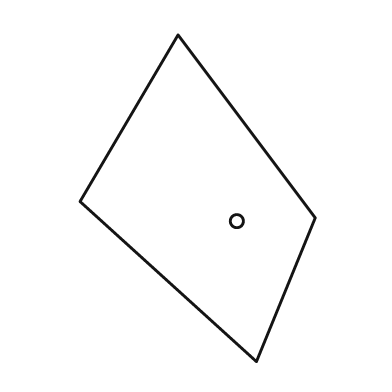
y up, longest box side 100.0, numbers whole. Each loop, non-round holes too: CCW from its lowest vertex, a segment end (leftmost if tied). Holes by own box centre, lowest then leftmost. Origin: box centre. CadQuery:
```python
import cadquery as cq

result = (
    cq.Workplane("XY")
    .moveTo(18.0, -50.0)
    .lineTo(36.0, -6.0)
    .lineTo(-6.0, 50.0)
    .lineTo(-36.0, -1.0)
    .close()
    .moveTo(12.0, -7.0)
    .circle(2.0)
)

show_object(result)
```